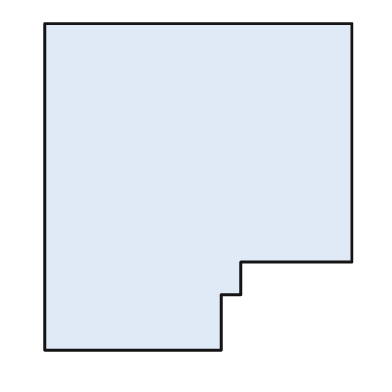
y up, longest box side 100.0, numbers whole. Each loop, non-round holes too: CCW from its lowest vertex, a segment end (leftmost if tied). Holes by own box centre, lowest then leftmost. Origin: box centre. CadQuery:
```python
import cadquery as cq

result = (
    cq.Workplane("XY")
    .moveTo(-47.0, -50.0)
    .lineTo(7.0, -50.0)
    .lineTo(7.0, -33.0)
    .lineTo(13.0, -33.0)
    .lineTo(13.0, -23.0)
    .lineTo(47.0, -23.0)
    .lineTo(47.0, 50.0)
    .lineTo(-47.0, 50.0)
    .close()
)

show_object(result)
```